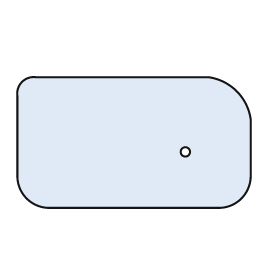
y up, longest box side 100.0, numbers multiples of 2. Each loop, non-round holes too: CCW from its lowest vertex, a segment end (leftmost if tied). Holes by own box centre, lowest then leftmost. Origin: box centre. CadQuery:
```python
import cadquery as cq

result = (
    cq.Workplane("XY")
    .moveTo(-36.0, -28.0)
    .lineTo(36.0, -28.0)
    .threePointArc((46.0, -24.0), (50.0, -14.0))
    .lineTo(50.0, 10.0)
    .threePointArc((44.0, 22.0), (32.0, 28.0))
    .lineTo(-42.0, 28.0)
    .threePointArc((-48.0, 26.0), (-50.0, 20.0))
    .lineTo(-50.0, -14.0)
    .threePointArc((-46.0, -24.0), (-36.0, -28.0))
    .close()
    .moveTo(22.0, -4.0)
    .circle(2.0)
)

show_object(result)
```